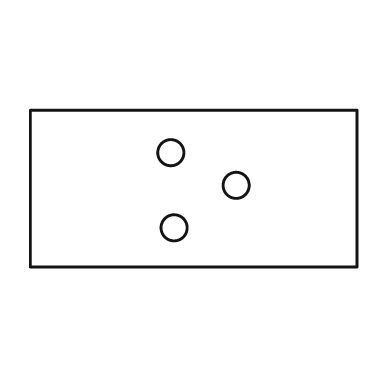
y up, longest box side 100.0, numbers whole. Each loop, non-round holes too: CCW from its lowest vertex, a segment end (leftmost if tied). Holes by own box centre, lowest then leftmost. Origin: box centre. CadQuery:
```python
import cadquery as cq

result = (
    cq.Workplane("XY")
    .moveTo(-50.0, -24.0)
    .lineTo(50.0, -24.0)
    .lineTo(50.0, 24.0)
    .lineTo(-50.0, 24.0)
    .close()
    .moveTo(-6.0, -12.0)
    .circle(4.0)
    .moveTo(13.0, 1.0)
    .circle(4.0)
    .moveTo(-7.0, 11.0)
    .circle(4.0)
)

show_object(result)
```